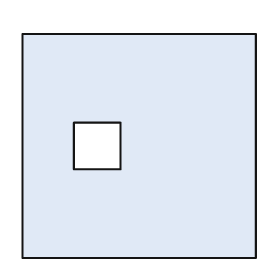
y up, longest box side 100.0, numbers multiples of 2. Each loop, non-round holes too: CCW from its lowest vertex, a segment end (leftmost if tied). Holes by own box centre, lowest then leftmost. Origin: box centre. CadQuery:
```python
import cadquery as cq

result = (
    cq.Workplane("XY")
    .moveTo(-50.0, -48.0)
    .lineTo(50.0, -48.0)
    .lineTo(50.0, 48.0)
    .lineTo(-50.0, 48.0)
    .close()
    .moveTo(-28.0, -10.0)
    .lineTo(-8.0, -10.0)
    .lineTo(-8.0, 10.0)
    .lineTo(-28.0, 10.0)
    .close()
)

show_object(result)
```